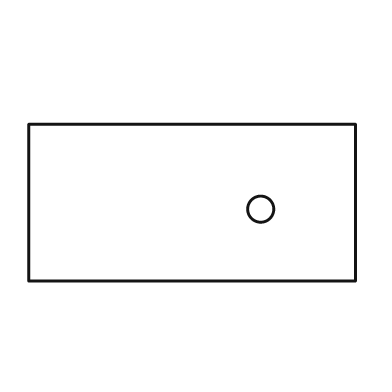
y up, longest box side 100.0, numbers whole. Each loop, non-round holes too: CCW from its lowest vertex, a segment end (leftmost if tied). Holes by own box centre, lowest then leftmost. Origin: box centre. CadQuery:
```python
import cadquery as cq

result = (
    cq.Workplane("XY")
    .moveTo(-50.0, -24.0)
    .lineTo(50.0, -24.0)
    .lineTo(50.0, 24.0)
    .lineTo(-50.0, 24.0)
    .close()
    .moveTo(21.0, -2.0)
    .circle(4.0)
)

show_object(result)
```